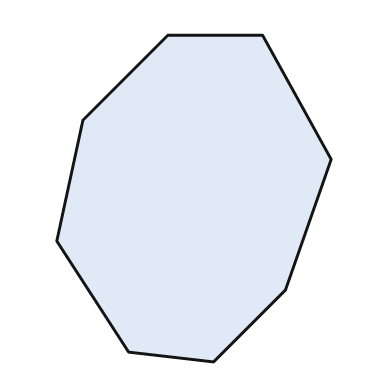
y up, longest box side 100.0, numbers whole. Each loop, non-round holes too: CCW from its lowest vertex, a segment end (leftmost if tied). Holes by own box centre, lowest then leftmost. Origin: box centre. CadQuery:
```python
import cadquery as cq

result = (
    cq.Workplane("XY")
    .moveTo(6.0, -50.0)
    .lineTo(28.0, -28.0)
    .lineTo(42.0, 12.0)
    .lineTo(21.0, 50.0)
    .lineTo(-8.0, 50.0)
    .lineTo(-34.0, 24.0)
    .lineTo(-42.0, -13.0)
    .lineTo(-20.0, -47.0)
    .close()
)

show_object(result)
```